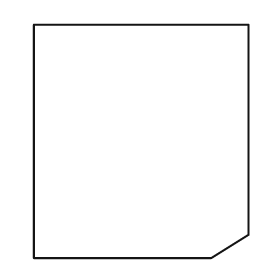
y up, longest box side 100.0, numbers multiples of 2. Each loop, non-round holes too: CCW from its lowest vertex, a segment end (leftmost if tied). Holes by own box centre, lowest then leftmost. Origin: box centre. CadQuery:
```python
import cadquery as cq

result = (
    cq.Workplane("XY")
    .moveTo(-46.0, -50.0)
    .lineTo(30.0, -50.0)
    .lineTo(46.0, -40.0)
    .lineTo(46.0, 50.0)
    .lineTo(-46.0, 50.0)
    .close()
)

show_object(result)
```